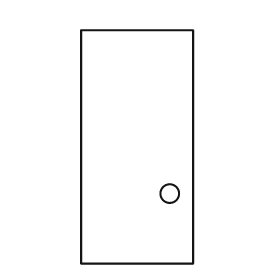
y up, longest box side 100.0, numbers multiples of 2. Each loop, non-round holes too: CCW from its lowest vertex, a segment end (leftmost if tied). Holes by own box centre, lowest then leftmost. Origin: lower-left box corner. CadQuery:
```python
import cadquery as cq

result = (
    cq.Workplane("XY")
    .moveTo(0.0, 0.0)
    .lineTo(48.0, 0.0)
    .lineTo(48.0, 100.0)
    .lineTo(0.0, 100.0)
    .close()
    .moveTo(38.0, 30.0)
    .circle(4.0)
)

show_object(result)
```